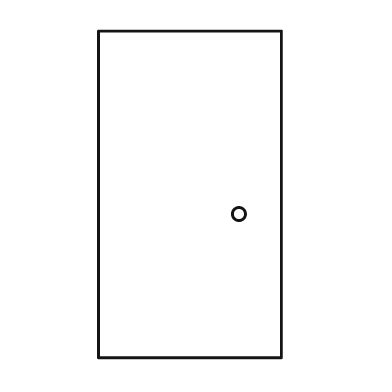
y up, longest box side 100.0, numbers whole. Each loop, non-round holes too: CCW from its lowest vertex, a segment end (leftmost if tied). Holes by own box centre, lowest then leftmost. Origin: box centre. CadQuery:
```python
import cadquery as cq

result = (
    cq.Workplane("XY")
    .moveTo(-28.0, -50.0)
    .lineTo(28.0, -50.0)
    .lineTo(28.0, 50.0)
    .lineTo(-28.0, 50.0)
    .close()
    .moveTo(15.0, -6.0)
    .circle(2.0)
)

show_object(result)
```